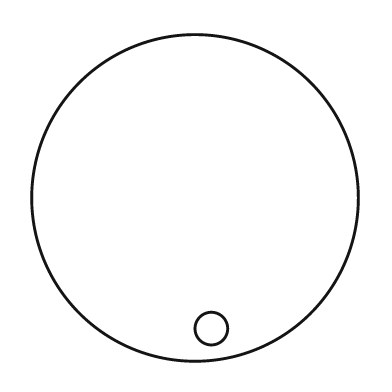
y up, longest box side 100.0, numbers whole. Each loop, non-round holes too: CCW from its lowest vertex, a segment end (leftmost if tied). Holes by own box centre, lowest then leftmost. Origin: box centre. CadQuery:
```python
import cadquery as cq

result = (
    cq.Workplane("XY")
    .moveTo(0.0, 0.0)
    .circle(50.0)
    .moveTo(5.0, -40.0)
    .circle(5.0)
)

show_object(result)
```